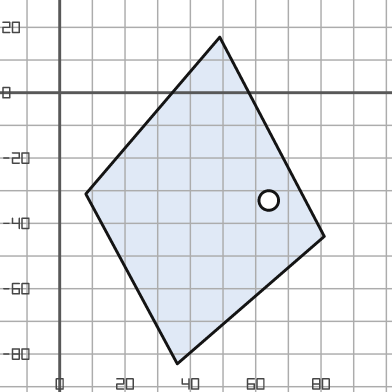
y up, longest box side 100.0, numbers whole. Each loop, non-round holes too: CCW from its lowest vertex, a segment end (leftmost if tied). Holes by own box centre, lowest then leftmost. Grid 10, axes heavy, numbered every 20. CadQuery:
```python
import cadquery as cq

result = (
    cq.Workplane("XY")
    .moveTo(36.0, -83.0)
    .lineTo(81.0, -44.0)
    .lineTo(49.0, 17.0)
    .lineTo(8.0, -31.0)
    .close()
    .moveTo(64.0, -33.0)
    .circle(3.0)
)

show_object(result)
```